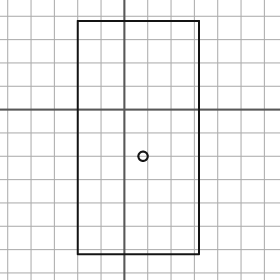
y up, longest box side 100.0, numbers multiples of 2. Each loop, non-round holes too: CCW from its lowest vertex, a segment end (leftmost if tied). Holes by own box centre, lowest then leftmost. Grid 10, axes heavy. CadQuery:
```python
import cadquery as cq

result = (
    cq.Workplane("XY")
    .moveTo(-20.0, -62.0)
    .lineTo(32.0, -62.0)
    .lineTo(32.0, 38.0)
    .lineTo(-20.0, 38.0)
    .close()
    .moveTo(8.0, -20.0)
    .circle(2.0)
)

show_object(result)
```